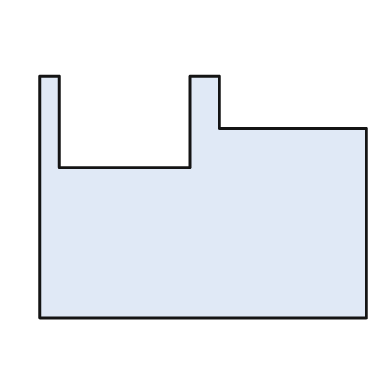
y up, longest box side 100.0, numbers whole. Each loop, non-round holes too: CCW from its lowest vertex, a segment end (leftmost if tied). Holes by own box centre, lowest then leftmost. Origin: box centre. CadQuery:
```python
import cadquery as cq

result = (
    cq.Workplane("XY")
    .moveTo(-50.0, -37.0)
    .lineTo(50.0, -37.0)
    .lineTo(50.0, 21.0)
    .lineTo(5.0, 21.0)
    .lineTo(5.0, 37.0)
    .lineTo(-4.0, 37.0)
    .lineTo(-4.0, 9.0)
    .lineTo(-44.0, 9.0)
    .lineTo(-44.0, 37.0)
    .lineTo(-50.0, 37.0)
    .close()
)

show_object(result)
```